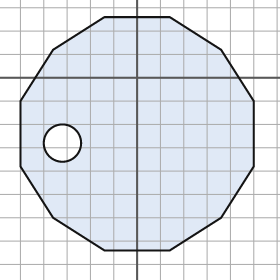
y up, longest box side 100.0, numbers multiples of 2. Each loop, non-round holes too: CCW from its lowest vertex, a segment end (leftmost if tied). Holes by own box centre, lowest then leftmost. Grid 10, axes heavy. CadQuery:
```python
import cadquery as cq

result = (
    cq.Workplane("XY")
    .moveTo(-14.0, -74.0)
    .lineTo(14.0, -74.0)
    .lineTo(36.0, -60.0)
    .lineTo(50.0, -38.0)
    .lineTo(50.0, -10.0)
    .lineTo(36.0, 12.0)
    .lineTo(14.0, 26.0)
    .lineTo(-14.0, 26.0)
    .lineTo(-36.0, 12.0)
    .lineTo(-50.0, -10.0)
    .lineTo(-50.0, -38.0)
    .lineTo(-36.0, -60.0)
    .close()
    .moveTo(-32.0, -28.0)
    .circle(8.0)
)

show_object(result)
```